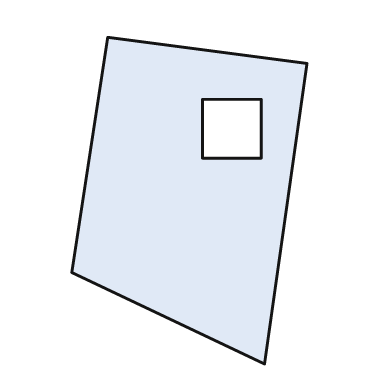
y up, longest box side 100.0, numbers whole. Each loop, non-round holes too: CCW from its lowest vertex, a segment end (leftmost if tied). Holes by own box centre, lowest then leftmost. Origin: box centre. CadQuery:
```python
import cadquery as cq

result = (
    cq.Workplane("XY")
    .moveTo(23.0, -50.0)
    .lineTo(36.0, 42.0)
    .lineTo(-25.0, 50.0)
    .lineTo(-36.0, -22.0)
    .close()
    .moveTo(4.0, 13.0)
    .lineTo(22.0, 13.0)
    .lineTo(22.0, 31.0)
    .lineTo(4.0, 31.0)
    .close()
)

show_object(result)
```